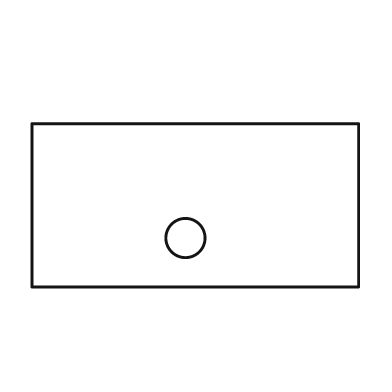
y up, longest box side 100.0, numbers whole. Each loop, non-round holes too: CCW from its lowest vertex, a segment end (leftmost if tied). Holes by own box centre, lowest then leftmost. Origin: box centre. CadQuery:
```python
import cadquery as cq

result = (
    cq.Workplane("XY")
    .moveTo(-50.0, -25.0)
    .lineTo(50.0, -25.0)
    .lineTo(50.0, 25.0)
    .lineTo(-50.0, 25.0)
    .close()
    .moveTo(-3.0, -10.0)
    .circle(6.0)
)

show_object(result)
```